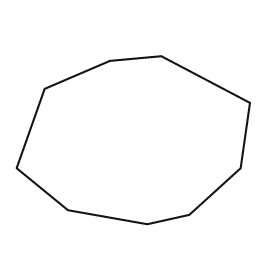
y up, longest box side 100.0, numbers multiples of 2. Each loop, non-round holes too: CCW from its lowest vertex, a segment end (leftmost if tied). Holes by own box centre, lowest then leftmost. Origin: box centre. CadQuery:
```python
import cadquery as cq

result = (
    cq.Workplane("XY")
    .moveTo(6.0, -36.0)
    .lineTo(24.0, -32.0)
    .lineTo(46.0, -12.0)
    .lineTo(50.0, 16.0)
    .lineTo(12.0, 36.0)
    .lineTo(-10.0, 34.0)
    .lineTo(-38.0, 22.0)
    .lineTo(-50.0, -12.0)
    .lineTo(-28.0, -30.0)
    .close()
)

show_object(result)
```